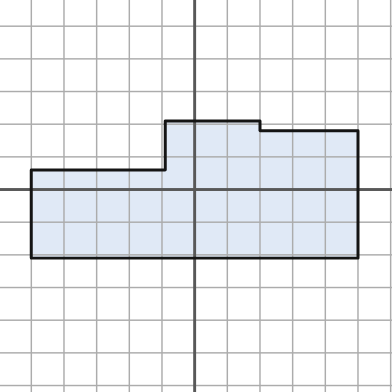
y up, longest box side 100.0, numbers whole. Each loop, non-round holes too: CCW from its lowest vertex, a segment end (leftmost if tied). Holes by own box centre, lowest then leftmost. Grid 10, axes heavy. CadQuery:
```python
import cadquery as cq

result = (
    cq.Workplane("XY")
    .moveTo(-50.0, -21.0)
    .lineTo(50.0, -21.0)
    .lineTo(50.0, 18.0)
    .lineTo(20.0, 18.0)
    .lineTo(20.0, 21.0)
    .lineTo(-9.0, 21.0)
    .lineTo(-9.0, 6.0)
    .lineTo(-50.0, 6.0)
    .close()
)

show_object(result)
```